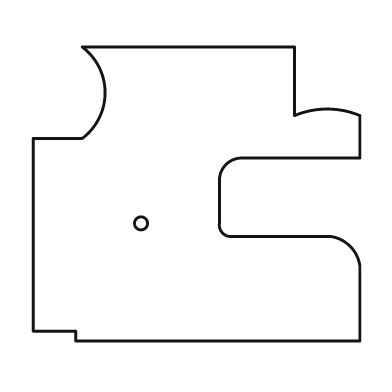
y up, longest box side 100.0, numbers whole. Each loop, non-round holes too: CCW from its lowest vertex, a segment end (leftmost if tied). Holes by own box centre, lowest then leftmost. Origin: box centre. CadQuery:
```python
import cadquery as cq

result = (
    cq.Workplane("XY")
    .moveTo(-37.0, -45.0)
    .lineTo(50.0, -45.0)
    .lineTo(50.0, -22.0)
    .threePointArc((47.0, -16.0), (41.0, -13.0))
    .lineTo(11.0, -13.0)
    .threePointArc((8.0, -12.0), (7.0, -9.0))
    .lineTo(7.0, 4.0)
    .threePointArc((9.0, 9.0), (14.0, 11.0))
    .lineTo(50.0, 11.0)
    .lineTo(50.0, 24.0)
    .threePointArc((40.0, 26.0), (30.0, 24.0))
    .lineTo(30.0, 45.0)
    .lineTo(-35.0, 45.0)
    .threePointArc((-28.0, 31.0), (-35.0, 17.0))
    .lineTo(-50.0, 17.0)
    .lineTo(-50.0, -42.0)
    .lineTo(-37.0, -42.0)
    .close()
    .moveTo(-17.0, -9.0)
    .circle(2.0)
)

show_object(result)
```